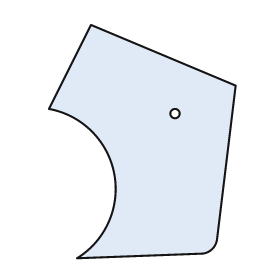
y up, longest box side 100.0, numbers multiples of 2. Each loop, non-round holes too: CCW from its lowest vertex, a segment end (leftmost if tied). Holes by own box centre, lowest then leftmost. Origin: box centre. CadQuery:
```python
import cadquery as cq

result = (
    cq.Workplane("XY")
    .moveTo(-28.0, -50.0)
    .lineTo(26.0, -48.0)
    .threePointArc((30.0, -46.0), (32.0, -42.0))
    .lineTo(40.0, 24.0)
    .lineTo(-22.0, 50.0)
    .lineTo(-40.0, 14.0)
    .threePointArc((-12.0, -14.0), (-28.0, -50.0))
    .close()
    .moveTo(14.0, 12.0)
    .circle(2.0)
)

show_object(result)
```